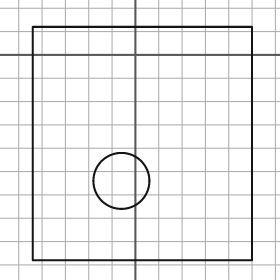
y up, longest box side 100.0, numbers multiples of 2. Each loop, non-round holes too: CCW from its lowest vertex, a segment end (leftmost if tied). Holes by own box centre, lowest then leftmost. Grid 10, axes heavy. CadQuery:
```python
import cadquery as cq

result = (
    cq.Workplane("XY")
    .moveTo(-44.0, -88.0)
    .lineTo(50.0, -88.0)
    .lineTo(50.0, 12.0)
    .lineTo(-44.0, 12.0)
    .close()
    .moveTo(-6.0, -54.0)
    .circle(12.0)
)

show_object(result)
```